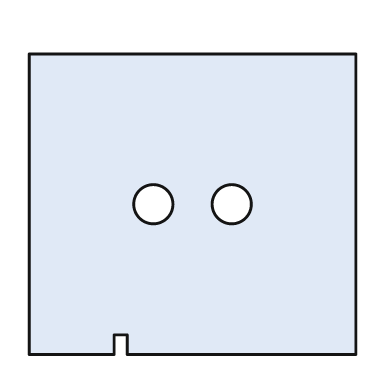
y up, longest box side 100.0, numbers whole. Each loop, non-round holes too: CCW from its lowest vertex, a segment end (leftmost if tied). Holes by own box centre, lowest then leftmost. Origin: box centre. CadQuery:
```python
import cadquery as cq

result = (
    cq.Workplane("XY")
    .moveTo(-50.0, -46.0)
    .lineTo(-24.0, -46.0)
    .lineTo(-24.0, -40.0)
    .lineTo(-20.0, -40.0)
    .lineTo(-20.0, -46.0)
    .lineTo(50.0, -46.0)
    .lineTo(50.0, 46.0)
    .lineTo(-50.0, 46.0)
    .close()
    .moveTo(-12.0, 0.0)
    .circle(6.0)
    .moveTo(12.0, 0.0)
    .circle(6.0)
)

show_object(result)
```